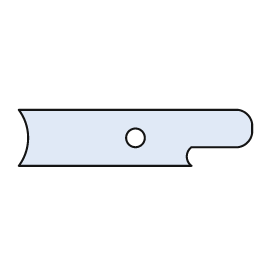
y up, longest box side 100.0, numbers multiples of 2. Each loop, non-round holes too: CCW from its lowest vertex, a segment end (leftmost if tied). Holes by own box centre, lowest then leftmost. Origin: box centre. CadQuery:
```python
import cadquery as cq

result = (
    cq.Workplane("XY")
    .moveTo(-50.0, -12.0)
    .lineTo(24.0, -12.0)
    .threePointArc((22.0, -8.0), (24.0, -4.0))
    .lineTo(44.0, -4.0)
    .threePointArc((48.0, -2.0), (50.0, 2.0))
    .lineTo(50.0, 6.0)
    .threePointArc((48.0, 10.0), (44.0, 12.0))
    .lineTo(-50.0, 12.0)
    .threePointArc((-46.0, 0.0), (-50.0, -12.0))
    .close()
    .moveTo(0.0, 0.0)
    .circle(4.0)
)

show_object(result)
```